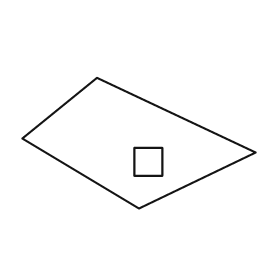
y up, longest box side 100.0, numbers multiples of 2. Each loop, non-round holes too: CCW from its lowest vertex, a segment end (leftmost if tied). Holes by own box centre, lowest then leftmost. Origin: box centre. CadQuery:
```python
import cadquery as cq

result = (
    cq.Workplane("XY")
    .moveTo(0.0, -28.0)
    .lineTo(50.0, -4.0)
    .lineTo(-18.0, 28.0)
    .lineTo(-50.0, 2.0)
    .close()
    .moveTo(-2.0, -14.0)
    .lineTo(10.0, -14.0)
    .lineTo(10.0, -2.0)
    .lineTo(-2.0, -2.0)
    .close()
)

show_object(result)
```